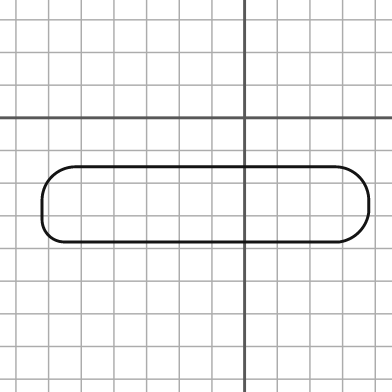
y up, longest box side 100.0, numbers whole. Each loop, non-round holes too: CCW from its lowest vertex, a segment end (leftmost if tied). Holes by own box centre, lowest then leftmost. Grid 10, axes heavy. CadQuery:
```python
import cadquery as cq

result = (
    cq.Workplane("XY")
    .moveTo(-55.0, -38.0)
    .lineTo(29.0, -38.0)
    .threePointArc((35.0, -35.0), (38.0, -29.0))
    .lineTo(38.0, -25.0)
    .threePointArc((35.0, -18.0), (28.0, -15.0))
    .lineTo(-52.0, -15.0)
    .threePointArc((-59.0, -18.0), (-62.0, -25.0))
    .lineTo(-62.0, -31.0)
    .threePointArc((-60.0, -36.0), (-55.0, -38.0))
    .close()
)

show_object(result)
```